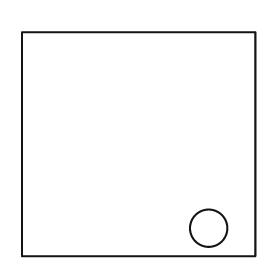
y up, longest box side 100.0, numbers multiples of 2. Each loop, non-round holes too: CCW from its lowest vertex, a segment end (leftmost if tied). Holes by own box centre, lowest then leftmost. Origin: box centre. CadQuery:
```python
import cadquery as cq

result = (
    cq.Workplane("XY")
    .moveTo(-50.0, -48.0)
    .lineTo(50.0, -48.0)
    .lineTo(50.0, 48.0)
    .lineTo(-50.0, 48.0)
    .close()
    .moveTo(30.0, -36.0)
    .circle(8.0)
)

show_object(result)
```